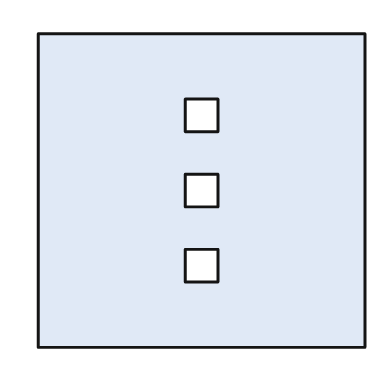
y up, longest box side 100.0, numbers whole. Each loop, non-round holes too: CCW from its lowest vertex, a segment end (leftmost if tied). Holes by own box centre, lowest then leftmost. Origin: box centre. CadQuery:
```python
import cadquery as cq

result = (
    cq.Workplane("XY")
    .moveTo(-50.0, -48.0)
    .lineTo(50.0, -48.0)
    .lineTo(50.0, 48.0)
    .lineTo(-50.0, 48.0)
    .close()
    .moveTo(-5.0, -28.0)
    .lineTo(5.0, -28.0)
    .lineTo(5.0, -18.0)
    .lineTo(-5.0, -18.0)
    .close()
    .moveTo(-5.0, -5.0)
    .lineTo(5.0, -5.0)
    .lineTo(5.0, 5.0)
    .lineTo(-5.0, 5.0)
    .close()
    .moveTo(-5.0, 18.0)
    .lineTo(5.0, 18.0)
    .lineTo(5.0, 28.0)
    .lineTo(-5.0, 28.0)
    .close()
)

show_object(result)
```